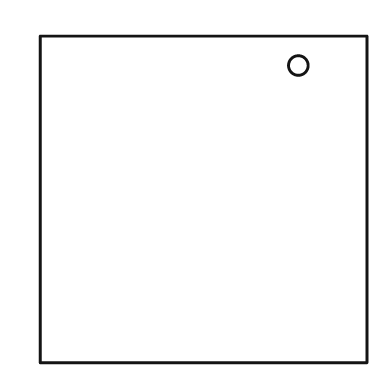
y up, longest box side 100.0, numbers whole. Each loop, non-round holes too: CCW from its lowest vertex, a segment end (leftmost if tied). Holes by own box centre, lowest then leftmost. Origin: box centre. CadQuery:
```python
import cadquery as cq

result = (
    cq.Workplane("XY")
    .moveTo(-50.0, -50.0)
    .lineTo(50.0, -50.0)
    .lineTo(50.0, 50.0)
    .lineTo(-50.0, 50.0)
    .close()
    .moveTo(29.0, 41.0)
    .circle(3.0)
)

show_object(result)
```